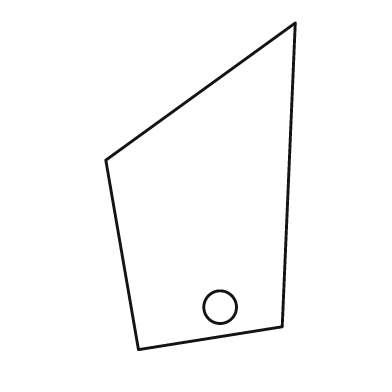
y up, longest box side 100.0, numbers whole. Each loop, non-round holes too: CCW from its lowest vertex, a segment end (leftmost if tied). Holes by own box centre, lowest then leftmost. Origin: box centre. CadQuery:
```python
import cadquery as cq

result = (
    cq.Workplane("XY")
    .moveTo(-19.0, -50.0)
    .lineTo(25.0, -43.0)
    .lineTo(29.0, 50.0)
    .lineTo(-29.0, 8.0)
    .close()
    .moveTo(6.0, -37.0)
    .circle(5.0)
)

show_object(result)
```